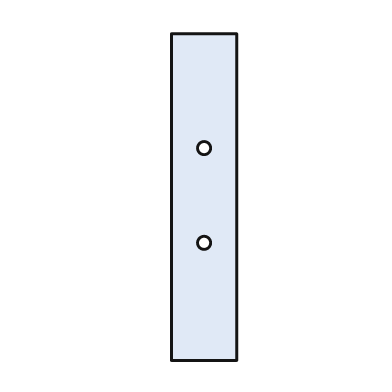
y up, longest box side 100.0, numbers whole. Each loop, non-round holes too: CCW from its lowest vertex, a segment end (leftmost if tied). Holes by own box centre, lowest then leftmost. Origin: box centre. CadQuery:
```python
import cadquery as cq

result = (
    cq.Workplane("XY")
    .moveTo(-10.0, -50.0)
    .lineTo(10.0, -50.0)
    .lineTo(10.0, 50.0)
    .lineTo(-10.0, 50.0)
    .close()
    .moveTo(0.0, -14.0)
    .circle(2.0)
    .moveTo(0.0, 15.0)
    .circle(2.0)
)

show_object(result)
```